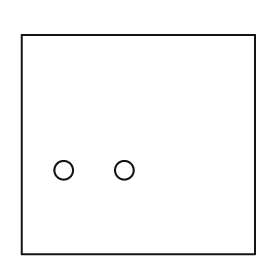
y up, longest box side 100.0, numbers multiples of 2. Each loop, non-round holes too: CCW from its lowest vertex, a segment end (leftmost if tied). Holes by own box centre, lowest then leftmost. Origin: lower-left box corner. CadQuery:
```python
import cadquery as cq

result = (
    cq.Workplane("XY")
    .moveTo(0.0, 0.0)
    .lineTo(100.0, 0.0)
    .lineTo(100.0, 94.0)
    .lineTo(0.0, 94.0)
    .close()
    .moveTo(18.0, 36.0)
    .circle(4.0)
    .moveTo(44.0, 36.0)
    .circle(4.0)
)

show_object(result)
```